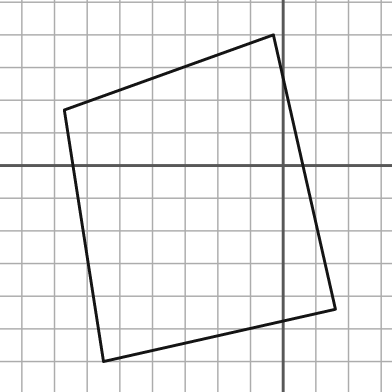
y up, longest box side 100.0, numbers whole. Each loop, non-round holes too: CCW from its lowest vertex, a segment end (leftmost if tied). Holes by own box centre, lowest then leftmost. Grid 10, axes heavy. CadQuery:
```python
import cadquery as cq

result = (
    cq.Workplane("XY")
    .moveTo(-55.0, -60.0)
    .lineTo(16.0, -44.0)
    .lineTo(-3.0, 40.0)
    .lineTo(-67.0, 17.0)
    .close()
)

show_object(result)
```